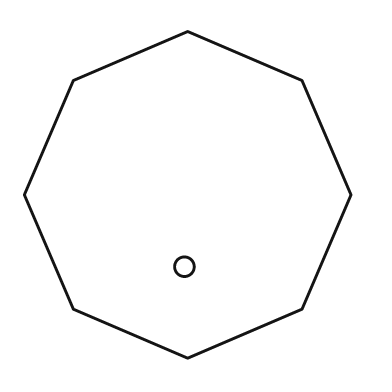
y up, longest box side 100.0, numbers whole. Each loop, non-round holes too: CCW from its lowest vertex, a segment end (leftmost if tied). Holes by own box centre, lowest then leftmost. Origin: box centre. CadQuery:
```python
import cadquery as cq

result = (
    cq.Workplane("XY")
    .moveTo(0.0, -50.0)
    .lineTo(35.0, -35.0)
    .lineTo(50.0, 0.0)
    .lineTo(35.0, 35.0)
    .lineTo(0.0, 50.0)
    .lineTo(-35.0, 35.0)
    .lineTo(-50.0, 0.0)
    .lineTo(-35.0, -35.0)
    .close()
    .moveTo(-1.0, -22.0)
    .circle(3.0)
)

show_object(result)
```